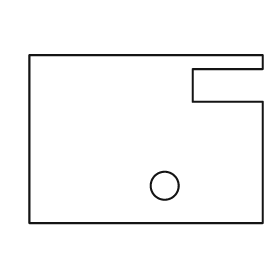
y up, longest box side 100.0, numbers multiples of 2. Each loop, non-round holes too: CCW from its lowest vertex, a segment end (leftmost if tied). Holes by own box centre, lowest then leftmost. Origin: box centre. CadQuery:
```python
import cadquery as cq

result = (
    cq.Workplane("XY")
    .moveTo(-50.0, -36.0)
    .lineTo(50.0, -36.0)
    .lineTo(50.0, 16.0)
    .lineTo(20.0, 16.0)
    .lineTo(20.0, 30.0)
    .lineTo(50.0, 30.0)
    .lineTo(50.0, 36.0)
    .lineTo(-50.0, 36.0)
    .close()
    .moveTo(8.0, -20.0)
    .circle(6.0)
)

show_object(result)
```